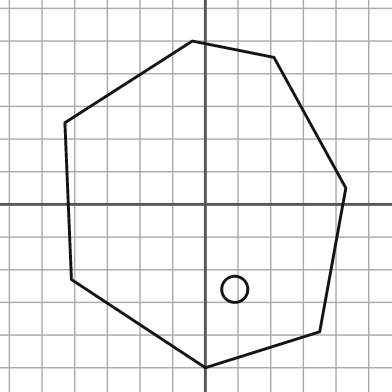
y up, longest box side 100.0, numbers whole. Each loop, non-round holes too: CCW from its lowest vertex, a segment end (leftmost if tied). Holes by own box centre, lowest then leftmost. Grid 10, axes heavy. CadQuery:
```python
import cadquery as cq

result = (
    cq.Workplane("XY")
    .moveTo(0.0, -50.0)
    .lineTo(35.0, -39.0)
    .lineTo(43.0, 5.0)
    .lineTo(21.0, 45.0)
    .lineTo(-4.0, 50.0)
    .lineTo(-43.0, 25.0)
    .lineTo(-41.0, -23.0)
    .close()
    .moveTo(9.0, -26.0)
    .circle(4.0)
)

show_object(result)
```